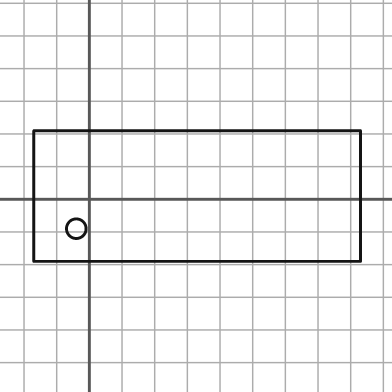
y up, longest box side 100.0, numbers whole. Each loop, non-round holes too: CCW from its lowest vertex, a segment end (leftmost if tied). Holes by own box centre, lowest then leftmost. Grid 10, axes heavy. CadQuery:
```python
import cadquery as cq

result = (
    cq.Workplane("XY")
    .moveTo(-17.0, -19.0)
    .lineTo(83.0, -19.0)
    .lineTo(83.0, 21.0)
    .lineTo(-17.0, 21.0)
    .close()
    .moveTo(-4.0, -9.0)
    .circle(3.0)
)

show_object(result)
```